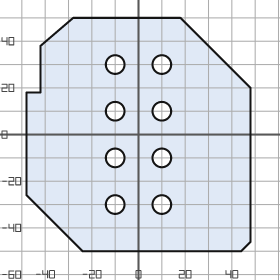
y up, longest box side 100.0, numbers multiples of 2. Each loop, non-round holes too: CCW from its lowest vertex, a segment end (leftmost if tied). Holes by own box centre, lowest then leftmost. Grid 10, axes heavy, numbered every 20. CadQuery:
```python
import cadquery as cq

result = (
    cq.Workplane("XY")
    .moveTo(-24.0, -50.0)
    .lineTo(44.0, -50.0)
    .lineTo(48.0, -46.0)
    .lineTo(48.0, 20.0)
    .lineTo(18.0, 50.0)
    .lineTo(-28.0, 50.0)
    .lineTo(-42.0, 38.0)
    .lineTo(-42.0, 18.0)
    .lineTo(-48.0, 18.0)
    .lineTo(-48.0, -26.0)
    .close()
    .moveTo(-10.0, -30.0)
    .circle(4.0)
    .moveTo(10.0, -30.0)
    .circle(4.0)
    .moveTo(-10.0, -10.0)
    .circle(4.0)
    .moveTo(10.0, -10.0)
    .circle(4.0)
    .moveTo(-10.0, 10.0)
    .circle(4.0)
    .moveTo(10.0, 10.0)
    .circle(4.0)
    .moveTo(-10.0, 30.0)
    .circle(4.0)
    .moveTo(10.0, 30.0)
    .circle(4.0)
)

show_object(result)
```